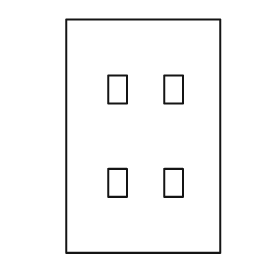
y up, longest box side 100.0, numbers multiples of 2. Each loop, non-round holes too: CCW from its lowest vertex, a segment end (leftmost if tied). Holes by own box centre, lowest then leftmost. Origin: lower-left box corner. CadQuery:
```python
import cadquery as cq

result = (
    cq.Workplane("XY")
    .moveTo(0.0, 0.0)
    .lineTo(66.0, 0.0)
    .lineTo(66.0, 100.0)
    .lineTo(0.0, 100.0)
    .close()
    .moveTo(18.0, 24.0)
    .lineTo(26.0, 24.0)
    .lineTo(26.0, 36.0)
    .lineTo(18.0, 36.0)
    .close()
    .moveTo(42.0, 24.0)
    .lineTo(50.0, 24.0)
    .lineTo(50.0, 36.0)
    .lineTo(42.0, 36.0)
    .close()
    .moveTo(18.0, 64.0)
    .lineTo(26.0, 64.0)
    .lineTo(26.0, 76.0)
    .lineTo(18.0, 76.0)
    .close()
    .moveTo(42.0, 64.0)
    .lineTo(50.0, 64.0)
    .lineTo(50.0, 76.0)
    .lineTo(42.0, 76.0)
    .close()
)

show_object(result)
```